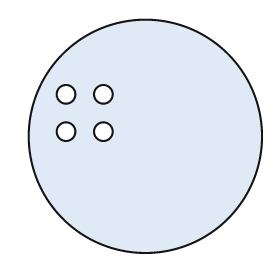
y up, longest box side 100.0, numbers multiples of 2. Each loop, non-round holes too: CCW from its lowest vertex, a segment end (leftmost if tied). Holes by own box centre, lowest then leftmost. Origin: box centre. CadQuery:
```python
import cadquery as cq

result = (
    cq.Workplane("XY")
    .moveTo(0.0, 0.0)
    .circle(50.0)
    .moveTo(-34.0, 2.0)
    .circle(4.0)
    .moveTo(-18.0, 2.0)
    .circle(4.0)
    .moveTo(-34.0, 18.0)
    .circle(4.0)
    .moveTo(-18.0, 18.0)
    .circle(4.0)
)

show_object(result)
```